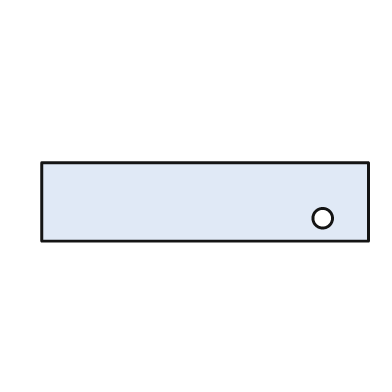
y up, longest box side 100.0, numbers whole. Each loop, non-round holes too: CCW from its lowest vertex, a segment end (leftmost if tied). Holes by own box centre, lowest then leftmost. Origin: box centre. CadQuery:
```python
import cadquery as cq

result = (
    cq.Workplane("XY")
    .moveTo(-50.0, -12.0)
    .lineTo(50.0, -12.0)
    .lineTo(50.0, 12.0)
    .lineTo(-50.0, 12.0)
    .close()
    .moveTo(36.0, -5.0)
    .circle(3.0)
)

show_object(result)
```